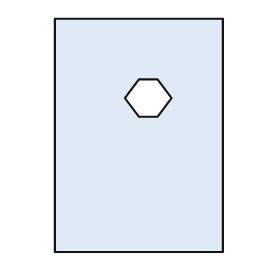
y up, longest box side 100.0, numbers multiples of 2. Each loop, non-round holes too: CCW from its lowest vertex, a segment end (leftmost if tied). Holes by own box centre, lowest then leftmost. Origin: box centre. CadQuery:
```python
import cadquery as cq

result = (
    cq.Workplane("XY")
    .moveTo(-36.0, -50.0)
    .lineTo(36.0, -50.0)
    .lineTo(36.0, 50.0)
    .lineTo(-36.0, 50.0)
    .close()
    .moveTo(0.0, 8.0)
    .lineTo(8.0, 8.0)
    .lineTo(14.0, 16.0)
    .lineTo(8.0, 24.0)
    .lineTo(0.0, 24.0)
    .lineTo(-6.0, 16.0)
    .close()
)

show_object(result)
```